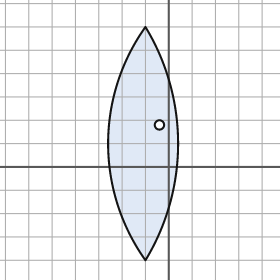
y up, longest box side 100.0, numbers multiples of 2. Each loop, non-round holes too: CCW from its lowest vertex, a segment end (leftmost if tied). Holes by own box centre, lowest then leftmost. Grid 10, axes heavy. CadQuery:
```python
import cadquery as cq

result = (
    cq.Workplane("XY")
    .moveTo(-10.0, -40.0)
    .threePointArc((4.0, 10.0), (-10.0, 60.0))
    .threePointArc((-26.0, 10.0), (-10.0, -40.0))
    .close()
    .moveTo(-4.0, 18.0)
    .circle(2.0)
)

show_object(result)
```